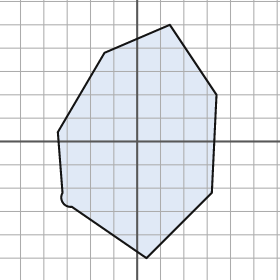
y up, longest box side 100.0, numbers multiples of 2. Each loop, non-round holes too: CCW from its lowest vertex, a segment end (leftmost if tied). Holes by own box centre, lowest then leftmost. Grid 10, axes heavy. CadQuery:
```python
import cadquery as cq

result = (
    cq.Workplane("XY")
    .moveTo(4.0, -50.0)
    .lineTo(32.0, -22.0)
    .lineTo(34.0, 20.0)
    .lineTo(14.0, 50.0)
    .lineTo(-14.0, 38.0)
    .lineTo(-34.0, 4.0)
    .lineTo(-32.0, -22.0)
    .threePointArc((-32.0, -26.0), (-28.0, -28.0))
    .close()
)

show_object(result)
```